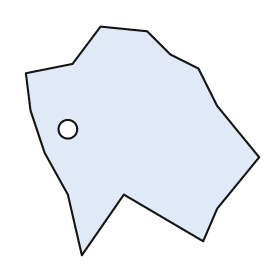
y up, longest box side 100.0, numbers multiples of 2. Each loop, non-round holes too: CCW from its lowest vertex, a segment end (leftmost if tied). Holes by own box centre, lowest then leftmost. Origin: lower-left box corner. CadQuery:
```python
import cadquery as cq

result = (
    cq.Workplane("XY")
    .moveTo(24.0, 0.0)
    .lineTo(42.0, 26.0)
    .lineTo(76.0, 6.0)
    .lineTo(82.0, 20.0)
    .lineTo(100.0, 42.0)
    .lineTo(82.0, 64.0)
    .lineTo(74.0, 80.0)
    .lineTo(62.0, 86.0)
    .lineTo(52.0, 96.0)
    .lineTo(32.0, 98.0)
    .lineTo(20.0, 82.0)
    .lineTo(0.0, 78.0)
    .lineTo(2.0, 62.0)
    .lineTo(8.0, 44.0)
    .lineTo(18.0, 26.0)
    .close()
    .moveTo(18.0, 54.0)
    .circle(4.0)
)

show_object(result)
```